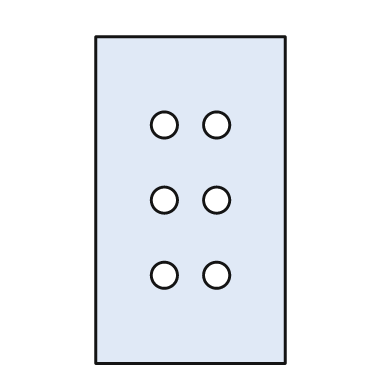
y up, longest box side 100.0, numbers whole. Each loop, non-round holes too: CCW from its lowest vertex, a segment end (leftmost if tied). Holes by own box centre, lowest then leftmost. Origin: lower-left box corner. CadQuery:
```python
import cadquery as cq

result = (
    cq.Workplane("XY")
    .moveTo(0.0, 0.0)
    .lineTo(58.0, 0.0)
    .lineTo(58.0, 100.0)
    .lineTo(0.0, 100.0)
    .close()
    .moveTo(21.0, 27.0)
    .circle(4.0)
    .moveTo(37.0, 27.0)
    .circle(4.0)
    .moveTo(21.0, 50.0)
    .circle(4.0)
    .moveTo(37.0, 50.0)
    .circle(4.0)
    .moveTo(21.0, 73.0)
    .circle(4.0)
    .moveTo(37.0, 73.0)
    .circle(4.0)
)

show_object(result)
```